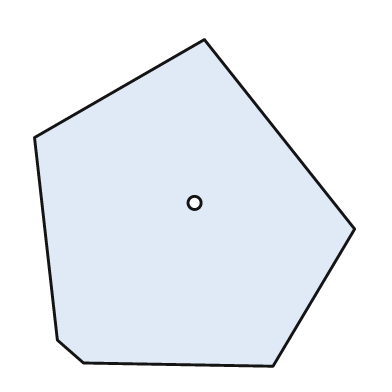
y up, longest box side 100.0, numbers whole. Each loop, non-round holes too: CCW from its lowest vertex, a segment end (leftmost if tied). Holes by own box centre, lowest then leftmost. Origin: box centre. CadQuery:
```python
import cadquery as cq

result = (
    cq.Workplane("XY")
    .moveTo(24.0, -50.0)
    .lineTo(49.0, -8.0)
    .lineTo(3.0, 50.0)
    .lineTo(-49.0, 20.0)
    .lineTo(-42.0, -42.0)
    .lineTo(-34.0, -49.0)
    .close()
    .moveTo(0.0, 0.0)
    .circle(2.0)
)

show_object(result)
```